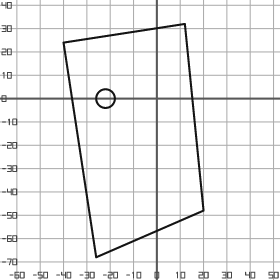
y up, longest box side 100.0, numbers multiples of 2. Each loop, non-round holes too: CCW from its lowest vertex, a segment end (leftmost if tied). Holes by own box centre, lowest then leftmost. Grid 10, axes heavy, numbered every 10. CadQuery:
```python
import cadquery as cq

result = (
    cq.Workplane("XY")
    .moveTo(-26.0, -68.0)
    .lineTo(20.0, -48.0)
    .lineTo(12.0, 32.0)
    .lineTo(-40.0, 24.0)
    .close()
    .moveTo(-22.0, 0.0)
    .circle(4.0)
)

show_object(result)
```